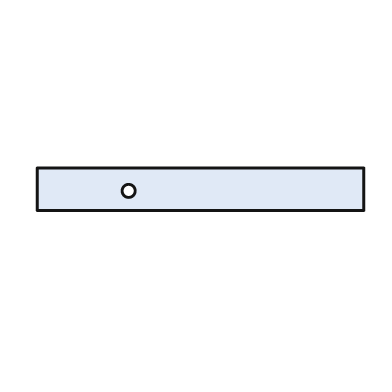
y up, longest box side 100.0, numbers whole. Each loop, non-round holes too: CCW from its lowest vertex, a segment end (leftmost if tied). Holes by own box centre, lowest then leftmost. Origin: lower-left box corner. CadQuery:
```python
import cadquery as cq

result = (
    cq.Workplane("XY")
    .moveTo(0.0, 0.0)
    .lineTo(100.0, 0.0)
    .lineTo(100.0, 13.0)
    .lineTo(0.0, 13.0)
    .close()
    .moveTo(28.0, 6.0)
    .circle(2.0)
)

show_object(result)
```